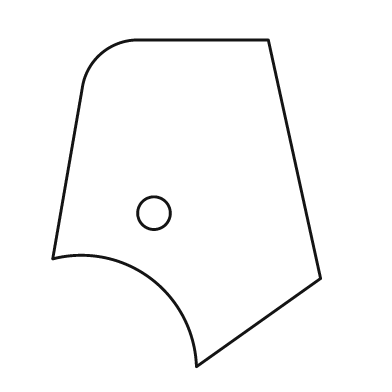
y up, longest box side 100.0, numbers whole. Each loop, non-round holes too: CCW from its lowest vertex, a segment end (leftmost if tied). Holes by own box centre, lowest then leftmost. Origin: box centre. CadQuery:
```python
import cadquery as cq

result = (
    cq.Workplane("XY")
    .moveTo(3.0, -50.0)
    .lineTo(41.0, -23.0)
    .lineTo(25.0, 50.0)
    .lineTo(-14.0, 50.0)
    .threePointArc((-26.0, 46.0), (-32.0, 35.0))
    .lineTo(-41.0, -17.0)
    .threePointArc((-11.0, -23.0), (3.0, -50.0))
    .close()
    .moveTo(-10.0, -3.0)
    .circle(5.0)
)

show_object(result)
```